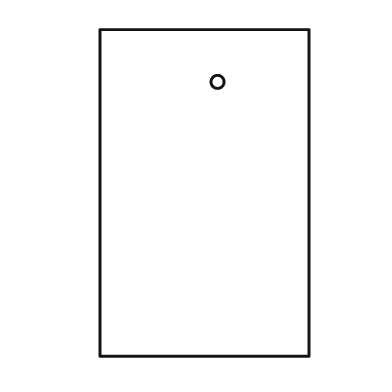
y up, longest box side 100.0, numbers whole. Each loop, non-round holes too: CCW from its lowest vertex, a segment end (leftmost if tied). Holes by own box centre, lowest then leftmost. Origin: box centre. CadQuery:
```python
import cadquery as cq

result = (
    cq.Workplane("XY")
    .moveTo(-32.0, -50.0)
    .lineTo(32.0, -50.0)
    .lineTo(32.0, 50.0)
    .lineTo(-32.0, 50.0)
    .close()
    .moveTo(4.0, 34.0)
    .circle(2.0)
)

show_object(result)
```